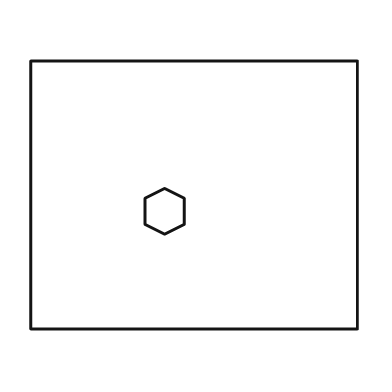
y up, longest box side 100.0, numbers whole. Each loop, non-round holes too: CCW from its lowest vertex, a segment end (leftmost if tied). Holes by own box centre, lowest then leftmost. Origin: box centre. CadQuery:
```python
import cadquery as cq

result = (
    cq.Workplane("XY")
    .moveTo(-50.0, -41.0)
    .lineTo(50.0, -41.0)
    .lineTo(50.0, 41.0)
    .lineTo(-50.0, 41.0)
    .close()
    .moveTo(-9.0, -12.0)
    .lineTo(-3.0, -9.0)
    .lineTo(-3.0, -1.0)
    .lineTo(-9.0, 2.0)
    .lineTo(-15.0, -1.0)
    .lineTo(-15.0, -9.0)
    .close()
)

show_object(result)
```